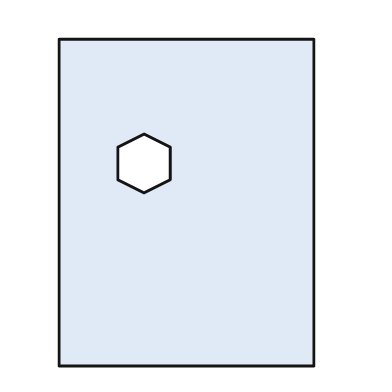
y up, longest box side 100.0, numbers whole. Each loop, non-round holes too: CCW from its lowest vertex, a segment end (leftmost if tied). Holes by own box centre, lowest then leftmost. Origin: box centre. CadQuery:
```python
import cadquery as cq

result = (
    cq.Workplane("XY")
    .moveTo(-39.0, -50.0)
    .lineTo(39.0, -50.0)
    .lineTo(39.0, 50.0)
    .lineTo(-39.0, 50.0)
    .close()
    .moveTo(-13.0, 3.0)
    .lineTo(-5.0, 7.0)
    .lineTo(-5.0, 17.0)
    .lineTo(-13.0, 21.0)
    .lineTo(-21.0, 17.0)
    .lineTo(-21.0, 7.0)
    .close()
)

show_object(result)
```